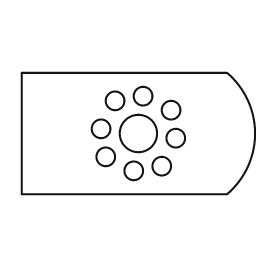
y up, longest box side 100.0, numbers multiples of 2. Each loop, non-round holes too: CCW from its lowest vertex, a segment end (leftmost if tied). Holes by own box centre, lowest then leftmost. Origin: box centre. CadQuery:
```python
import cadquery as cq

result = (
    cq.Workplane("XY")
    .moveTo(-50.0, -26.0)
    .lineTo(38.0, -26.0)
    .threePointArc((50.0, 0.0), (38.0, 26.0))
    .lineTo(-50.0, 26.0)
    .close()
    .moveTo(-2.0, -16.0)
    .circle(4.0)
    .moveTo(10.0, -14.0)
    .circle(4.0)
    .moveTo(-14.0, -10.0)
    .circle(4.0)
    .moveTo(16.0, -2.0)
    .circle(4.0)
    .moveTo(0.0, 0.0)
    .circle(8.0)
    .moveTo(-16.0, 2.0)
    .circle(4.0)
    .moveTo(14.0, 10.0)
    .circle(4.0)
    .moveTo(-10.0, 14.0)
    .circle(4.0)
    .moveTo(2.0, 16.0)
    .circle(4.0)
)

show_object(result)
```